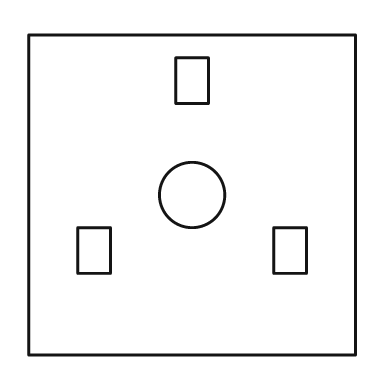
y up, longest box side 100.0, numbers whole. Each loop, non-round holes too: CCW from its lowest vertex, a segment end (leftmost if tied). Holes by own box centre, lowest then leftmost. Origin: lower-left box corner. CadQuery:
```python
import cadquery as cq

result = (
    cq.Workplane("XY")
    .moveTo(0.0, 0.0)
    .lineTo(100.0, 0.0)
    .lineTo(100.0, 98.0)
    .lineTo(0.0, 98.0)
    .close()
    .moveTo(15.0, 25.0)
    .lineTo(25.0, 25.0)
    .lineTo(25.0, 39.0)
    .lineTo(15.0, 39.0)
    .close()
    .moveTo(75.0, 25.0)
    .lineTo(85.0, 25.0)
    .lineTo(85.0, 39.0)
    .lineTo(75.0, 39.0)
    .close()
    .moveTo(50.0, 49.0)
    .circle(10.0)
    .moveTo(45.0, 77.0)
    .lineTo(55.0, 77.0)
    .lineTo(55.0, 91.0)
    .lineTo(45.0, 91.0)
    .close()
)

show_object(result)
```